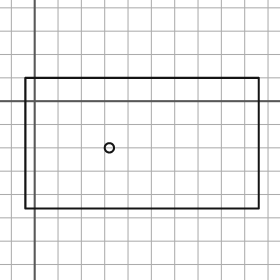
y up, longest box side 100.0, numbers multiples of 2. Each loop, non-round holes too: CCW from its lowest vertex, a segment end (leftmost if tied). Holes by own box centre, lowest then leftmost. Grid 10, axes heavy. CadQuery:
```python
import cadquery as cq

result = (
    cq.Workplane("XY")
    .moveTo(-4.0, -46.0)
    .lineTo(96.0, -46.0)
    .lineTo(96.0, 10.0)
    .lineTo(-4.0, 10.0)
    .close()
    .moveTo(32.0, -20.0)
    .circle(2.0)
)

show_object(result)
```